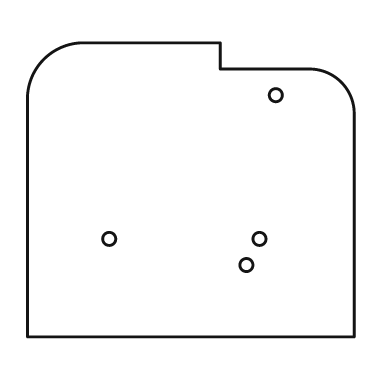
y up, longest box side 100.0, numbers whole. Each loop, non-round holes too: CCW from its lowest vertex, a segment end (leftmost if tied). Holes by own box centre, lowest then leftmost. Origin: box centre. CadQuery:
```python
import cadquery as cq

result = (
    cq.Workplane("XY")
    .moveTo(-50.0, -45.0)
    .lineTo(50.0, -45.0)
    .lineTo(50.0, 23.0)
    .threePointArc((46.0, 33.0), (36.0, 37.0))
    .lineTo(9.0, 37.0)
    .lineTo(9.0, 45.0)
    .lineTo(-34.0, 45.0)
    .threePointArc((-45.0, 40.0), (-50.0, 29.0))
    .close()
    .moveTo(17.0, -23.0)
    .circle(2.0)
    .moveTo(-25.0, -15.0)
    .circle(2.0)
    .moveTo(21.0, -15.0)
    .circle(2.0)
    .moveTo(26.0, 29.0)
    .circle(2.0)
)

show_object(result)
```